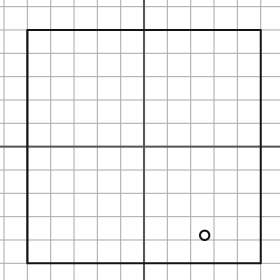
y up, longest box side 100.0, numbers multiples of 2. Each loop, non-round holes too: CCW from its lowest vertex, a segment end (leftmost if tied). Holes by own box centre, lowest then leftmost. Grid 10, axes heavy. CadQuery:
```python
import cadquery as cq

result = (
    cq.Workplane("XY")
    .moveTo(-50.0, -50.0)
    .lineTo(50.0, -50.0)
    .lineTo(50.0, 50.0)
    .lineTo(-50.0, 50.0)
    .close()
    .moveTo(26.0, -38.0)
    .circle(2.0)
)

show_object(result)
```